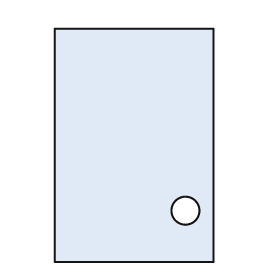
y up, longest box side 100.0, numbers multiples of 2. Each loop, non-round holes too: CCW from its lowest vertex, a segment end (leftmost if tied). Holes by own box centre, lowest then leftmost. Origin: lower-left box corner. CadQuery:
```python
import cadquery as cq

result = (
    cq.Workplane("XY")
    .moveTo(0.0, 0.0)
    .lineTo(68.0, 0.0)
    .lineTo(68.0, 100.0)
    .lineTo(0.0, 100.0)
    .close()
    .moveTo(56.0, 22.0)
    .circle(6.0)
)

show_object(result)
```